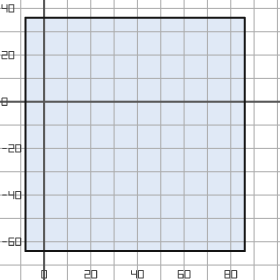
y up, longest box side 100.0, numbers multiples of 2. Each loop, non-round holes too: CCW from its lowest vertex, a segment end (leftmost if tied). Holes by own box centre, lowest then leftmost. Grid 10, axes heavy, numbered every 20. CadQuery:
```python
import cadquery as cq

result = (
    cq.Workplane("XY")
    .moveTo(-8.0, -64.0)
    .lineTo(86.0, -64.0)
    .lineTo(86.0, 36.0)
    .lineTo(-8.0, 36.0)
    .close()
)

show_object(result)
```